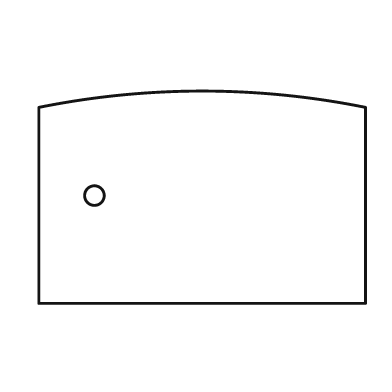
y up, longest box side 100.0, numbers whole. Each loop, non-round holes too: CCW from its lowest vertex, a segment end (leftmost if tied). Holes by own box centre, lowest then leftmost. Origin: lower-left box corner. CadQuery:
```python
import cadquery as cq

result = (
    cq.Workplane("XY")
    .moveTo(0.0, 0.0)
    .lineTo(100.0, 0.0)
    .lineTo(100.0, 60.0)
    .threePointArc((50.0, 65.0), (0.0, 60.0))
    .close()
    .moveTo(17.0, 33.0)
    .circle(3.0)
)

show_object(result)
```